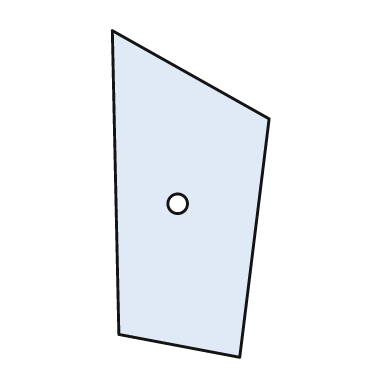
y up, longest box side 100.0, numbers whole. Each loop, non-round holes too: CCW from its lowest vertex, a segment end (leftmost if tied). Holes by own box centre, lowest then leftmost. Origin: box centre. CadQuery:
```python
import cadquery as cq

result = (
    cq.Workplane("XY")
    .moveTo(15.0, -50.0)
    .lineTo(24.0, 23.0)
    .lineTo(-24.0, 50.0)
    .lineTo(-22.0, -43.0)
    .close()
    .moveTo(-4.0, -3.0)
    .circle(3.0)
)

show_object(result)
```